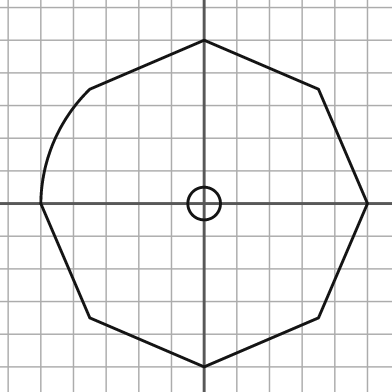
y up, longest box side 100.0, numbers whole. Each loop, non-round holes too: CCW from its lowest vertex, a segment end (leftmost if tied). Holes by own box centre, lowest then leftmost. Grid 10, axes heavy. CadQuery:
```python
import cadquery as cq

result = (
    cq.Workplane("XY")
    .moveTo(0.0, -50.0)
    .lineTo(35.0, -35.0)
    .lineTo(50.0, 0.0)
    .lineTo(35.0, 35.0)
    .lineTo(0.0, 50.0)
    .lineTo(-35.0, 35.0)
    .threePointArc((-46.0, 19.0), (-50.0, 0.0))
    .lineTo(-35.0, -35.0)
    .close()
    .moveTo(0.0, 0.0)
    .circle(5.0)
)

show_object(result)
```